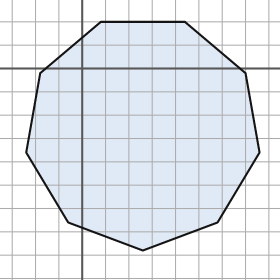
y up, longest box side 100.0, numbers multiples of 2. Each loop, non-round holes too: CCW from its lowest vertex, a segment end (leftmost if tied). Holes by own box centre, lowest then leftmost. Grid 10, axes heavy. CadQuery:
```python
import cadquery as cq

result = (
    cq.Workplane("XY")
    .moveTo(26.0, -78.0)
    .lineTo(58.0, -66.0)
    .lineTo(76.0, -36.0)
    .lineTo(70.0, -2.0)
    .lineTo(44.0, 20.0)
    .lineTo(8.0, 20.0)
    .lineTo(-18.0, -2.0)
    .lineTo(-24.0, -36.0)
    .lineTo(-6.0, -66.0)
    .close()
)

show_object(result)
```